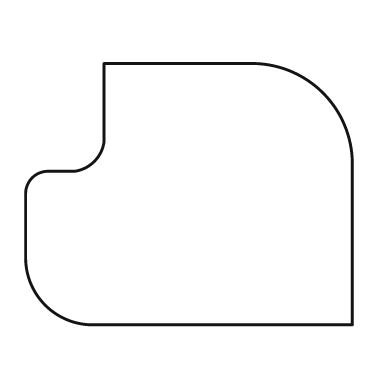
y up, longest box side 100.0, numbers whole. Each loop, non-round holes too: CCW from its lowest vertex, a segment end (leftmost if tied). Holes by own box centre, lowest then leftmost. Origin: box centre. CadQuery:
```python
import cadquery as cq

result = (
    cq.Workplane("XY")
    .moveTo(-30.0, -40.0)
    .lineTo(50.0, -40.0)
    .lineTo(50.0, 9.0)
    .threePointArc((41.0, 31.0), (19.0, 40.0))
    .lineTo(-26.0, 40.0)
    .lineTo(-26.0, 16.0)
    .threePointArc((-29.0, 10.0), (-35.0, 7.0))
    .lineTo(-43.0, 7.0)
    .threePointArc((-48.0, 5.0), (-50.0, 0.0))
    .lineTo(-50.0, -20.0)
    .threePointArc((-44.0, -34.0), (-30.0, -40.0))
    .close()
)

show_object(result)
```